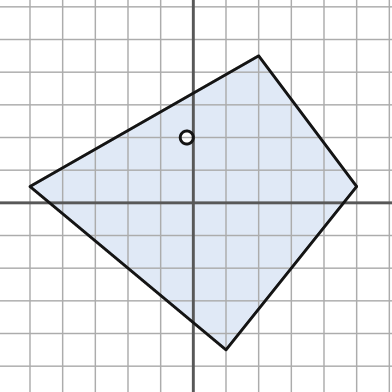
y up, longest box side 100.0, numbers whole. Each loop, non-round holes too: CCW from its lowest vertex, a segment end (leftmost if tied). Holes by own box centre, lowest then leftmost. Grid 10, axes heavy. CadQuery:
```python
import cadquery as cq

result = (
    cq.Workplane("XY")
    .moveTo(10.0, -45.0)
    .lineTo(50.0, 5.0)
    .lineTo(20.0, 45.0)
    .lineTo(-50.0, 5.0)
    .close()
    .moveTo(-2.0, 20.0)
    .circle(2.0)
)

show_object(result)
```